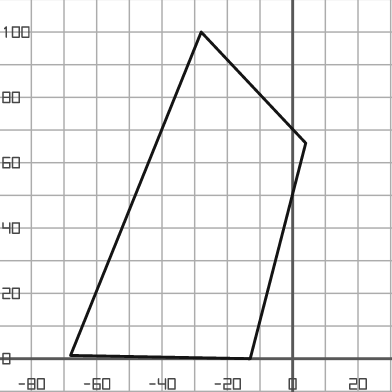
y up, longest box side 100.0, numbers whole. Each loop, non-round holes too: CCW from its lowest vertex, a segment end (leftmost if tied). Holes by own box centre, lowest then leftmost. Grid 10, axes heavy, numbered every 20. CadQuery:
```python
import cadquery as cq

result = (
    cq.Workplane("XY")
    .moveTo(-13.0, 0.0)
    .lineTo(4.0, 66.0)
    .lineTo(-28.0, 100.0)
    .lineTo(-68.0, 1.0)
    .close()
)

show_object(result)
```